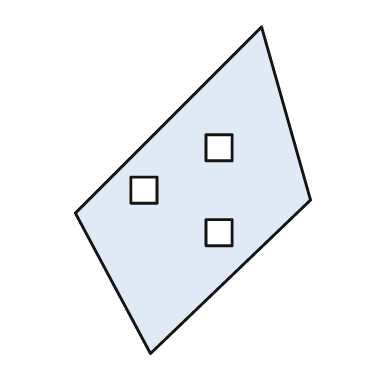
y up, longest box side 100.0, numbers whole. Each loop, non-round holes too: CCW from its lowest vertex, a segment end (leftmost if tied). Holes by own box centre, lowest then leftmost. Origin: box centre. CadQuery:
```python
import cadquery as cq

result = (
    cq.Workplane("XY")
    .moveTo(-13.0, -50.0)
    .lineTo(36.0, -3.0)
    .lineTo(21.0, 50.0)
    .lineTo(-36.0, -7.0)
    .close()
    .moveTo(4.0, -17.0)
    .lineTo(12.0, -17.0)
    .lineTo(12.0, -9.0)
    .lineTo(4.0, -9.0)
    .close()
    .moveTo(-19.0, -4.0)
    .lineTo(-11.0, -4.0)
    .lineTo(-11.0, 4.0)
    .lineTo(-19.0, 4.0)
    .close()
    .moveTo(4.0, 9.0)
    .lineTo(12.0, 9.0)
    .lineTo(12.0, 17.0)
    .lineTo(4.0, 17.0)
    .close()
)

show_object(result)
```